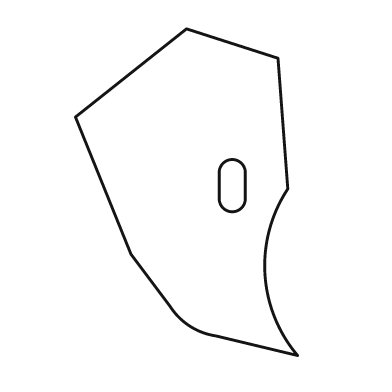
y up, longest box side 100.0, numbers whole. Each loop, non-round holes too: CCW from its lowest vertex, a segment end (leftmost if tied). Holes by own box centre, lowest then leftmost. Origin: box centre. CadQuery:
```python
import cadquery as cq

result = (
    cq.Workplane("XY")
    .moveTo(34.0, -50.0)
    .threePointArc((24.0, -25.0), (31.0, 1.0))
    .lineTo(28.0, 41.0)
    .lineTo(0.0, 50.0)
    .lineTo(-34.0, 23.0)
    .lineTo(-17.0, -19.0)
    .lineTo(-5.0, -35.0)
    .threePointArc((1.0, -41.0), (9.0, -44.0))
    .close()
    .moveTo(10.0, -2.0)
    .threePointArc((14.0, -6.0), (18.0, -2.0))
    .lineTo(18.0, 6.0)
    .threePointArc((14.0, 10.0), (10.0, 6.0))
    .close()
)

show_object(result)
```